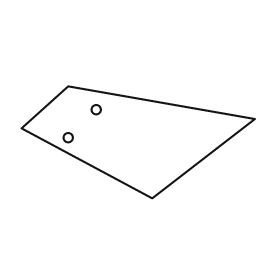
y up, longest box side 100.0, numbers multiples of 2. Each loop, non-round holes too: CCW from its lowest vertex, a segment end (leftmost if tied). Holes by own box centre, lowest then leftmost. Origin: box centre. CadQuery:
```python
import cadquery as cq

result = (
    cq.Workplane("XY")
    .moveTo(6.0, -24.0)
    .lineTo(50.0, 10.0)
    .lineTo(-30.0, 24.0)
    .lineTo(-50.0, 6.0)
    .close()
    .moveTo(-30.0, 2.0)
    .circle(2.0)
    .moveTo(-18.0, 14.0)
    .circle(2.0)
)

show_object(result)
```